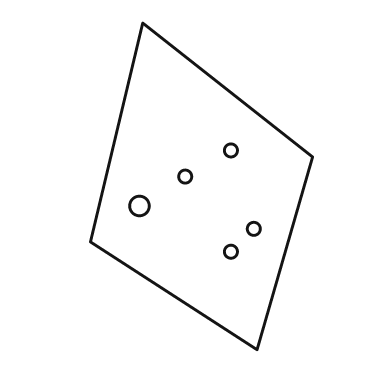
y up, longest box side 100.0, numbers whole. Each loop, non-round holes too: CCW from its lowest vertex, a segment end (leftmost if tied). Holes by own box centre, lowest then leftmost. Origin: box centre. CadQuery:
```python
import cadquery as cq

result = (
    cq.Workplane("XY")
    .moveTo(17.0, -50.0)
    .lineTo(34.0, 9.0)
    .lineTo(-18.0, 50.0)
    .lineTo(-34.0, -17.0)
    .close()
    .moveTo(9.0, -20.0)
    .circle(2.0)
    .moveTo(16.0, -13.0)
    .circle(2.0)
    .moveTo(-19.0, -6.0)
    .circle(3.0)
    .moveTo(-5.0, 3.0)
    .circle(2.0)
    .moveTo(9.0, 11.0)
    .circle(2.0)
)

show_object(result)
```